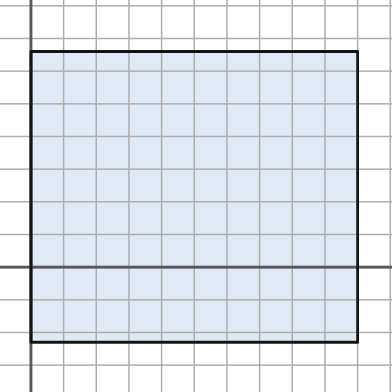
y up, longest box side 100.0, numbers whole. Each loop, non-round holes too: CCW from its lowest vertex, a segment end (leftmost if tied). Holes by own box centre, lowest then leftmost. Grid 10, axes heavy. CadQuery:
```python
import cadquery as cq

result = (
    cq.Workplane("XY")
    .moveTo(0.0, -23.0)
    .lineTo(100.0, -23.0)
    .lineTo(100.0, 66.0)
    .lineTo(0.0, 66.0)
    .close()
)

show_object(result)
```